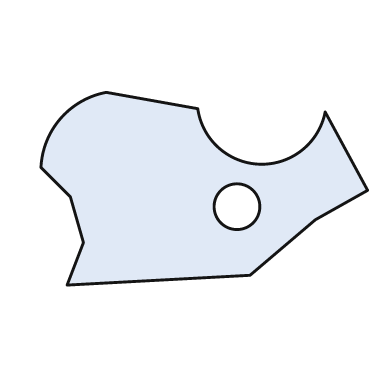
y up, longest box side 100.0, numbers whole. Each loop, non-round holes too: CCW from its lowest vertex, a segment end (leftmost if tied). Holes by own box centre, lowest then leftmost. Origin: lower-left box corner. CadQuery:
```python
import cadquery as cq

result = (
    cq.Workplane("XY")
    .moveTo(8.0, 0.0)
    .lineTo(64.0, 3.0)
    .lineTo(84.0, 20.0)
    .lineTo(100.0, 29.0)
    .lineTo(87.0, 53.0)
    .threePointArc((67.0, 37.0), (48.0, 54.0))
    .lineTo(20.0, 59.0)
    .threePointArc((6.0, 51.0), (0.0, 36.0))
    .lineTo(9.0, 27.0)
    .lineTo(13.0, 13.0)
    .close()
    .moveTo(60.0, 24.0)
    .circle(7.0)
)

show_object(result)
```